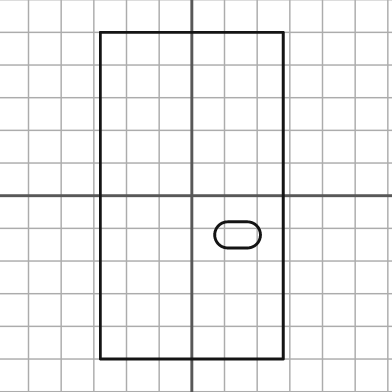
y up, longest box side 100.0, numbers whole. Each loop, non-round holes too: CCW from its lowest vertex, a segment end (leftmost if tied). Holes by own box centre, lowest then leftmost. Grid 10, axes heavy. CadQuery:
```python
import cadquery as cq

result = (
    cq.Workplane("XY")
    .moveTo(-28.0, -50.0)
    .lineTo(28.0, -50.0)
    .lineTo(28.0, 50.0)
    .lineTo(-28.0, 50.0)
    .close()
    .moveTo(11.0, -16.0)
    .lineTo(17.0, -16.0)
    .threePointArc((21.0, -12.0), (17.0, -8.0))
    .lineTo(11.0, -8.0)
    .threePointArc((7.0, -12.0), (11.0, -16.0))
    .close()
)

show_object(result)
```